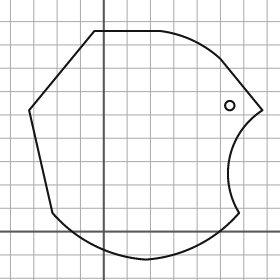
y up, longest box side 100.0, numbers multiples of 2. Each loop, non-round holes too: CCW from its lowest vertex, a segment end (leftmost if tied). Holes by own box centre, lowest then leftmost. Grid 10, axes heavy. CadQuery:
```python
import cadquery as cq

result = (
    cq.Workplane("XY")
    .moveTo(18.0, -12.0)
    .threePointArc((40.0, -6.0), (58.0, 8.0))
    .threePointArc((54.0, 32.0), (68.0, 52.0))
    .lineTo(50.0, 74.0)
    .threePointArc((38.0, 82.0), (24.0, 86.0))
    .lineTo(-4.0, 86.0)
    .lineTo(-32.0, 52.0)
    .lineTo(-22.0, 8.0)
    .threePointArc((-4.0, -6.0), (18.0, -12.0))
    .close()
    .moveTo(54.0, 54.0)
    .circle(2.0)
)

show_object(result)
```